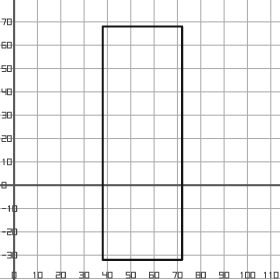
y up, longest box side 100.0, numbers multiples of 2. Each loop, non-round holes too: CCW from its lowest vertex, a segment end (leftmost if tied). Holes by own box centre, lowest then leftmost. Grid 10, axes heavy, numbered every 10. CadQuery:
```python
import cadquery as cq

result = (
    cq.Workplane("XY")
    .moveTo(38.0, -32.0)
    .lineTo(72.0, -32.0)
    .lineTo(72.0, 68.0)
    .lineTo(38.0, 68.0)
    .close()
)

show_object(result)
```